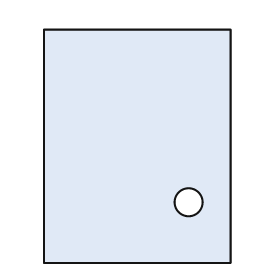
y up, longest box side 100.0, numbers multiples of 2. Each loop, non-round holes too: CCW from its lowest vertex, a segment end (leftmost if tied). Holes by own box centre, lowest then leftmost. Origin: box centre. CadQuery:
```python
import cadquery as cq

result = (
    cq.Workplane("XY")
    .moveTo(-40.0, -50.0)
    .lineTo(40.0, -50.0)
    .lineTo(40.0, 50.0)
    .lineTo(-40.0, 50.0)
    .close()
    .moveTo(22.0, -24.0)
    .circle(6.0)
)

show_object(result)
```